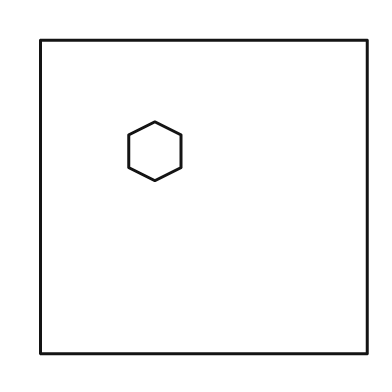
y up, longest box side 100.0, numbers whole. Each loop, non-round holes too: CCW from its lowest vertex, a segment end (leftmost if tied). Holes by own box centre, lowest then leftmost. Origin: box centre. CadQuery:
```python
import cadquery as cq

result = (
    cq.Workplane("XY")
    .moveTo(-50.0, -48.0)
    .lineTo(50.0, -48.0)
    .lineTo(50.0, 48.0)
    .lineTo(-50.0, 48.0)
    .close()
    .moveTo(-15.0, 5.0)
    .lineTo(-7.0, 9.0)
    .lineTo(-7.0, 19.0)
    .lineTo(-15.0, 23.0)
    .lineTo(-23.0, 19.0)
    .lineTo(-23.0, 9.0)
    .close()
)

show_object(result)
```